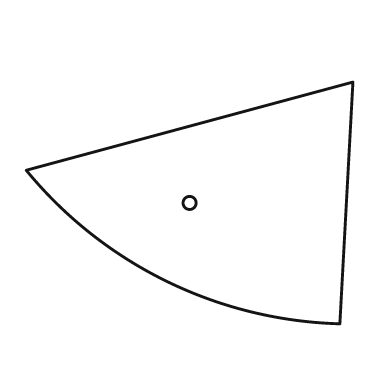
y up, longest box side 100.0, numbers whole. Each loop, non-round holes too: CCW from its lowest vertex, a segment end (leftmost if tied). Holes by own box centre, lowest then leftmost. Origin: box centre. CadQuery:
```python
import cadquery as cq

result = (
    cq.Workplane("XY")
    .moveTo(46.0, -37.0)
    .lineTo(50.0, 37.0)
    .lineTo(-50.0, 10.0)
    .threePointArc((-7.0, -24.0), (46.0, -37.0))
    .close()
    .moveTo(0.0, 0.0)
    .circle(2.0)
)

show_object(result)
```